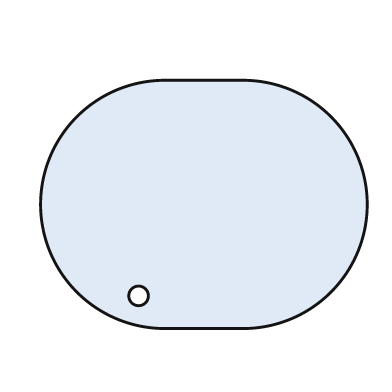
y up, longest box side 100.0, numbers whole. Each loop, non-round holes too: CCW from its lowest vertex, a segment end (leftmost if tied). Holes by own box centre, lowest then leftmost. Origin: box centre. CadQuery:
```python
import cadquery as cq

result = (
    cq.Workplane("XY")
    .moveTo(-12.0, -38.0)
    .lineTo(12.0, -38.0)
    .threePointArc((50.0, 0.0), (12.0, 38.0))
    .lineTo(-12.0, 38.0)
    .threePointArc((-50.0, 0.0), (-12.0, -38.0))
    .close()
    .moveTo(-20.0, -28.0)
    .circle(3.0)
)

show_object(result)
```